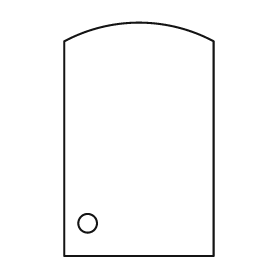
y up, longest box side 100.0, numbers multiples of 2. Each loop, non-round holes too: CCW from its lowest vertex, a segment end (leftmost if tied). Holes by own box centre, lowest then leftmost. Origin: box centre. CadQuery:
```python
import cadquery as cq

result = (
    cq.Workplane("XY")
    .moveTo(-32.0, -50.0)
    .lineTo(32.0, -50.0)
    .lineTo(32.0, 42.0)
    .threePointArc((0.0, 50.0), (-32.0, 42.0))
    .close()
    .moveTo(-22.0, -36.0)
    .circle(4.0)
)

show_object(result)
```